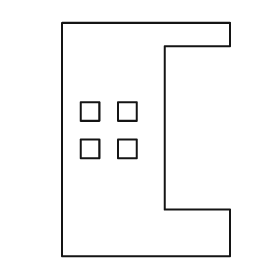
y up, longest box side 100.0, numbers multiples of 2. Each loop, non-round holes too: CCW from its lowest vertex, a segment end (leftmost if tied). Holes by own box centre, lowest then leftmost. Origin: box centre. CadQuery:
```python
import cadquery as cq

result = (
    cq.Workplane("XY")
    .moveTo(-36.0, -50.0)
    .lineTo(36.0, -50.0)
    .lineTo(36.0, -30.0)
    .lineTo(8.0, -30.0)
    .lineTo(8.0, 40.0)
    .lineTo(36.0, 40.0)
    .lineTo(36.0, 50.0)
    .lineTo(-36.0, 50.0)
    .close()
    .moveTo(-28.0, -8.0)
    .lineTo(-20.0, -8.0)
    .lineTo(-20.0, 0.0)
    .lineTo(-28.0, 0.0)
    .close()
    .moveTo(-12.0, -8.0)
    .lineTo(-4.0, -8.0)
    .lineTo(-4.0, 0.0)
    .lineTo(-12.0, 0.0)
    .close()
    .moveTo(-28.0, 8.0)
    .lineTo(-20.0, 8.0)
    .lineTo(-20.0, 16.0)
    .lineTo(-28.0, 16.0)
    .close()
    .moveTo(-12.0, 8.0)
    .lineTo(-4.0, 8.0)
    .lineTo(-4.0, 16.0)
    .lineTo(-12.0, 16.0)
    .close()
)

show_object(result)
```